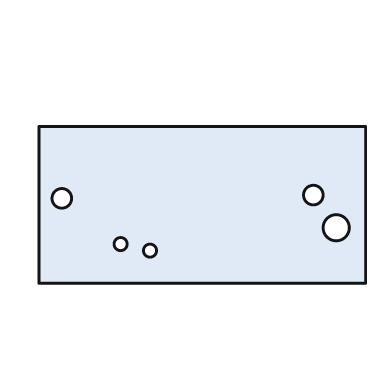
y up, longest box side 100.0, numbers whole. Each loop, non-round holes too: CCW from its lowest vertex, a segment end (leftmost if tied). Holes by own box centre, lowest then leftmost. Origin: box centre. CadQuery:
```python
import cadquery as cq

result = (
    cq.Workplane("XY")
    .moveTo(-50.0, -24.0)
    .lineTo(50.0, -24.0)
    .lineTo(50.0, 24.0)
    .lineTo(-50.0, 24.0)
    .close()
    .moveTo(-16.0, -14.0)
    .circle(2.0)
    .moveTo(-25.0, -12.0)
    .circle(2.0)
    .moveTo(41.0, -7.0)
    .circle(4.0)
    .moveTo(-43.0, 2.0)
    .circle(3.0)
    .moveTo(34.0, 3.0)
    .circle(3.0)
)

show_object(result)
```